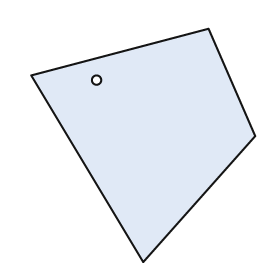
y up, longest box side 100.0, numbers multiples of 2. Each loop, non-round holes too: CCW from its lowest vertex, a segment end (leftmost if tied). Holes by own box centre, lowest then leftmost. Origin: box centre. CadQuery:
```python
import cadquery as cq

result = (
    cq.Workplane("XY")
    .moveTo(0.0, -50.0)
    .lineTo(48.0, 4.0)
    .lineTo(28.0, 50.0)
    .lineTo(-48.0, 30.0)
    .close()
    .moveTo(-20.0, 28.0)
    .circle(2.0)
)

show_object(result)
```